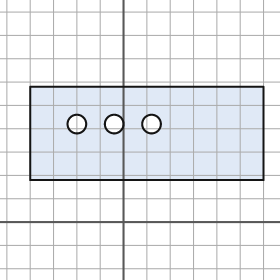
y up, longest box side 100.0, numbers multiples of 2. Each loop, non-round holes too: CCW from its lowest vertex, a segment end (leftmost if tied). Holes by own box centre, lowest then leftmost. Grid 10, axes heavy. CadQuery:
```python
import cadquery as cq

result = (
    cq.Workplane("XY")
    .moveTo(-40.0, 18.0)
    .lineTo(60.0, 18.0)
    .lineTo(60.0, 58.0)
    .lineTo(-40.0, 58.0)
    .close()
    .moveTo(-20.0, 42.0)
    .circle(4.0)
    .moveTo(-4.0, 42.0)
    .circle(4.0)
    .moveTo(12.0, 42.0)
    .circle(4.0)
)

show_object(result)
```